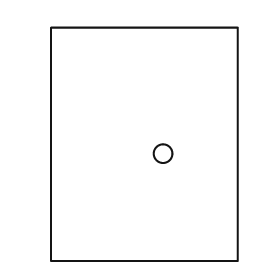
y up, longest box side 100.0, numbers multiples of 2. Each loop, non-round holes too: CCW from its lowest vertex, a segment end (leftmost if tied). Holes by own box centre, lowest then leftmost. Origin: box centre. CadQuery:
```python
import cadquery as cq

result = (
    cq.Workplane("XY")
    .moveTo(-40.0, -50.0)
    .lineTo(40.0, -50.0)
    .lineTo(40.0, 50.0)
    .lineTo(-40.0, 50.0)
    .close()
    .moveTo(8.0, -4.0)
    .circle(4.0)
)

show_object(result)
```